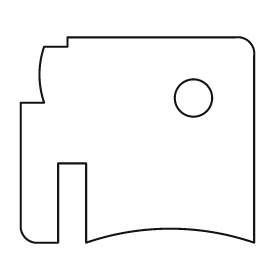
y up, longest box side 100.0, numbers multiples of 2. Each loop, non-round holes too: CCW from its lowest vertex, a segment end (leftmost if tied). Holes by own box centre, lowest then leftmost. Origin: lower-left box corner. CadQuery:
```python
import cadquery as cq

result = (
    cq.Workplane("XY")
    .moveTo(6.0, 0.0)
    .lineTo(16.0, 0.0)
    .lineTo(16.0, 34.0)
    .lineTo(28.0, 34.0)
    .lineTo(28.0, 0.0)
    .threePointArc((64.0, 6.0), (100.0, 0.0))
    .lineTo(100.0, 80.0)
    .threePointArc((98.0, 86.0), (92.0, 88.0))
    .lineTo(20.0, 88.0)
    .lineTo(20.0, 84.0)
    .lineTo(10.0, 84.0)
    .threePointArc((8.0, 72.0), (10.0, 60.0))
    .lineTo(0.0, 60.0)
    .lineTo(0.0, 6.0)
    .threePointArc((2.0, 2.0), (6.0, 0.0))
    .close()
    .moveTo(74.0, 62.0)
    .circle(8.0)
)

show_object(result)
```